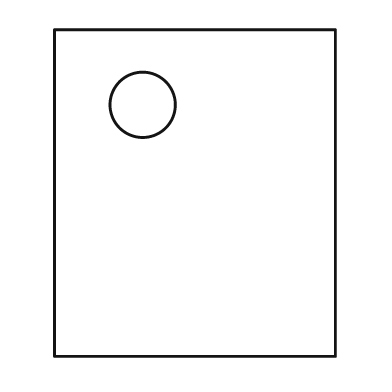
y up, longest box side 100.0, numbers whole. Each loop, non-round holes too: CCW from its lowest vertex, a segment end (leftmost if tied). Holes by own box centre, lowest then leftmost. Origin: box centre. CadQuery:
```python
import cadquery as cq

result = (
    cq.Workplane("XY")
    .moveTo(-43.0, -50.0)
    .lineTo(43.0, -50.0)
    .lineTo(43.0, 50.0)
    .lineTo(-43.0, 50.0)
    .close()
    .moveTo(-16.0, 27.0)
    .circle(10.0)
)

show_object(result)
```